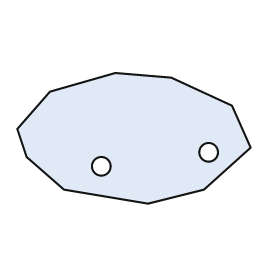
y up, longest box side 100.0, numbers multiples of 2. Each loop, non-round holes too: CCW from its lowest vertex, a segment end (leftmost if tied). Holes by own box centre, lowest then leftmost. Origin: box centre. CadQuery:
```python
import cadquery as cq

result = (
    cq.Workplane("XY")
    .moveTo(6.0, -28.0)
    .lineTo(30.0, -22.0)
    .lineTo(50.0, -4.0)
    .lineTo(42.0, 14.0)
    .lineTo(16.0, 26.0)
    .lineTo(-8.0, 28.0)
    .lineTo(-36.0, 20.0)
    .lineTo(-50.0, 4.0)
    .lineTo(-46.0, -8.0)
    .lineTo(-30.0, -22.0)
    .close()
    .moveTo(-14.0, -12.0)
    .circle(4.0)
    .moveTo(32.0, -6.0)
    .circle(4.0)
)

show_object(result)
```